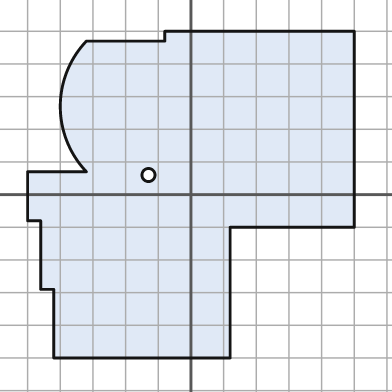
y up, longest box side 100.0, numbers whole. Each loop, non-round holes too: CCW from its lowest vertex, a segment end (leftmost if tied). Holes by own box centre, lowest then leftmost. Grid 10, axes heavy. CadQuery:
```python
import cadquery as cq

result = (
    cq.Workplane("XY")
    .moveTo(-42.0, -50.0)
    .lineTo(12.0, -50.0)
    .lineTo(12.0, -10.0)
    .lineTo(50.0, -10.0)
    .lineTo(50.0, 50.0)
    .lineTo(-8.0, 50.0)
    .lineTo(-8.0, 47.0)
    .lineTo(-32.0, 47.0)
    .threePointArc((-40.0, 27.0), (-32.0, 7.0))
    .lineTo(-50.0, 7.0)
    .lineTo(-50.0, -8.0)
    .lineTo(-46.0, -8.0)
    .lineTo(-46.0, -29.0)
    .lineTo(-42.0, -29.0)
    .close()
    .moveTo(-13.0, 6.0)
    .circle(2.0)
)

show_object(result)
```